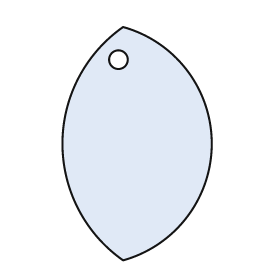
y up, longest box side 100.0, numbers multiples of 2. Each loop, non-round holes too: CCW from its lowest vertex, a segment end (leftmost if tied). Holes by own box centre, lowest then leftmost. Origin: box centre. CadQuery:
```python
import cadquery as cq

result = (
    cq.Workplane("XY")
    .moveTo(-6.0, -50.0)
    .threePointArc((32.0, 0.0), (-6.0, 50.0))
    .threePointArc((-32.0, 0.0), (-6.0, -50.0))
    .close()
    .moveTo(-8.0, 36.0)
    .circle(4.0)
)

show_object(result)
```